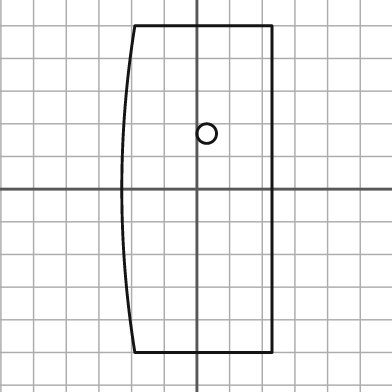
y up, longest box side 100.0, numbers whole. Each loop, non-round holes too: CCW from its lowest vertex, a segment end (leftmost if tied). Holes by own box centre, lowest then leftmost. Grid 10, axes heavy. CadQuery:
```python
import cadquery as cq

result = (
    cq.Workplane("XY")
    .moveTo(-19.0, -50.0)
    .lineTo(23.0, -50.0)
    .lineTo(23.0, 50.0)
    .lineTo(-19.0, 50.0)
    .threePointArc((-23.0, 0.0), (-19.0, -50.0))
    .close()
    .moveTo(3.0, 17.0)
    .circle(3.0)
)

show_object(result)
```